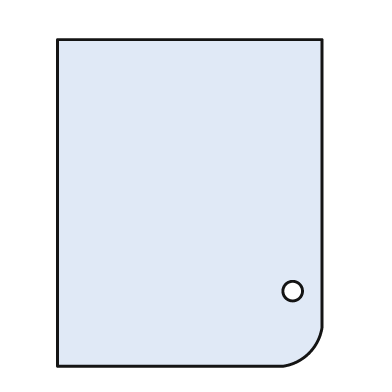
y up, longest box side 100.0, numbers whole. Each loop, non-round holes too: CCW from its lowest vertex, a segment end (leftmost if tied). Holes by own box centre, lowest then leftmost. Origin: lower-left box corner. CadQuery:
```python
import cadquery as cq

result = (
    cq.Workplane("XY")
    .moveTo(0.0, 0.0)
    .lineTo(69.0, 0.0)
    .threePointArc((77.0, 4.0), (81.0, 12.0))
    .lineTo(81.0, 100.0)
    .lineTo(0.0, 100.0)
    .close()
    .moveTo(72.0, 23.0)
    .circle(3.0)
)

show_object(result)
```